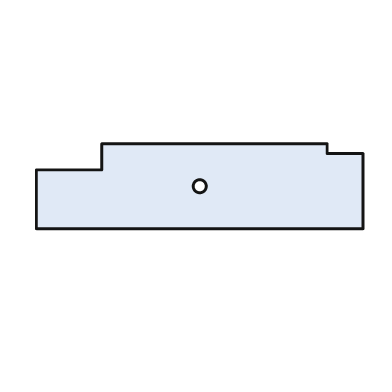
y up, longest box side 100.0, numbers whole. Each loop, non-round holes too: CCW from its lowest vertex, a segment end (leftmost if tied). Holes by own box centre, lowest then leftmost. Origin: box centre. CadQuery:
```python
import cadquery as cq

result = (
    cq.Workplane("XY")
    .moveTo(-50.0, -13.0)
    .lineTo(50.0, -13.0)
    .lineTo(50.0, 10.0)
    .lineTo(39.0, 10.0)
    .lineTo(39.0, 13.0)
    .lineTo(-30.0, 13.0)
    .lineTo(-30.0, 5.0)
    .lineTo(-50.0, 5.0)
    .close()
    .moveTo(0.0, 0.0)
    .circle(2.0)
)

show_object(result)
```